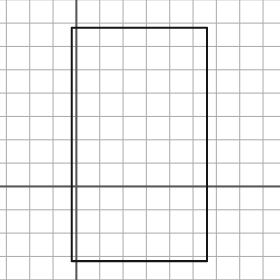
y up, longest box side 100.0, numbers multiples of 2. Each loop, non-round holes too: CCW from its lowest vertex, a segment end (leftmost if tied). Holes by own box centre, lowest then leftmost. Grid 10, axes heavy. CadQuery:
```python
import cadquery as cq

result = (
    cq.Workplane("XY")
    .moveTo(-2.0, -32.0)
    .lineTo(56.0, -32.0)
    .lineTo(56.0, 68.0)
    .lineTo(-2.0, 68.0)
    .close()
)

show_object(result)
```